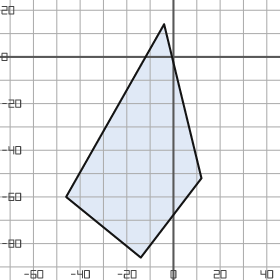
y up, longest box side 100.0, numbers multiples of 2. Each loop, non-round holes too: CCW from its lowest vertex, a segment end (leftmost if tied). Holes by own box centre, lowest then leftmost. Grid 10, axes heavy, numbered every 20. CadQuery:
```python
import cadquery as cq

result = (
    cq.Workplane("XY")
    .moveTo(-14.0, -86.0)
    .lineTo(12.0, -52.0)
    .lineTo(-4.0, 14.0)
    .lineTo(-46.0, -60.0)
    .close()
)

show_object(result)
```